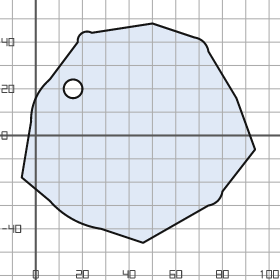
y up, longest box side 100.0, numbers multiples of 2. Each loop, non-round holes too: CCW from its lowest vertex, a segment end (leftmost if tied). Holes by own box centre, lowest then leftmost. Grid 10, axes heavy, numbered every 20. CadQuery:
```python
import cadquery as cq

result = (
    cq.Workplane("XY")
    .moveTo(46.0, -46.0)
    .lineTo(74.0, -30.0)
    .threePointArc((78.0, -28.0), (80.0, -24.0))
    .lineTo(94.0, -6.0)
    .lineTo(86.0, 16.0)
    .lineTo(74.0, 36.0)
    .threePointArc((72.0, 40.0), (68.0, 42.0))
    .lineTo(50.0, 48.0)
    .lineTo(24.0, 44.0)
    .threePointArc((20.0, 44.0), (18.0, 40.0))
    .lineTo(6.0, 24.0)
    .threePointArc((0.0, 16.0), (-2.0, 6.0))
    .lineTo(-6.0, -18.0)
    .lineTo(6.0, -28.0)
    .threePointArc((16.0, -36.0), (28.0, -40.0))
    .close()
    .moveTo(16.0, 20.0)
    .circle(4.0)
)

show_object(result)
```